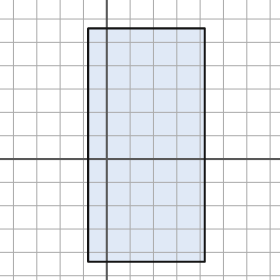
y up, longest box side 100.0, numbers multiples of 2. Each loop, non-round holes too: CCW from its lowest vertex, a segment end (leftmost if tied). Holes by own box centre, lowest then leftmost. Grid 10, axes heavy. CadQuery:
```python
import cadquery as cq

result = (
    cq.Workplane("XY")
    .moveTo(-8.0, -44.0)
    .lineTo(42.0, -44.0)
    .lineTo(42.0, 56.0)
    .lineTo(-8.0, 56.0)
    .close()
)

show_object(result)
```